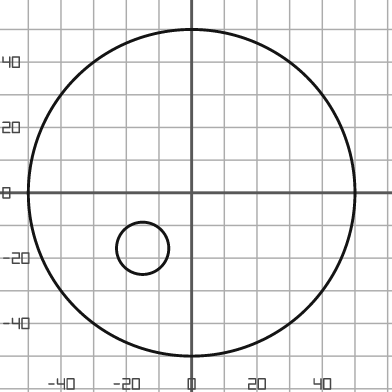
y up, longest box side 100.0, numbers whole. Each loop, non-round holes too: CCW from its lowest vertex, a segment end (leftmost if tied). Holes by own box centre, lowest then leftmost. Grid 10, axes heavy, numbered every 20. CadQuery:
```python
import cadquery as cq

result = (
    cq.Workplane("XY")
    .moveTo(0.0, 0.0)
    .circle(50.0)
    .moveTo(-15.0, -17.0)
    .circle(8.0)
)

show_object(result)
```